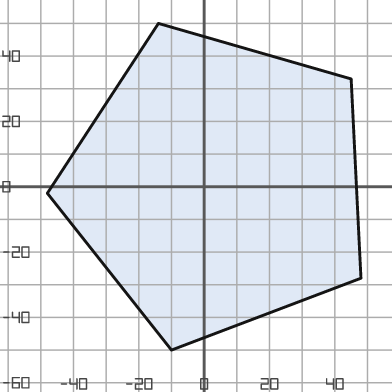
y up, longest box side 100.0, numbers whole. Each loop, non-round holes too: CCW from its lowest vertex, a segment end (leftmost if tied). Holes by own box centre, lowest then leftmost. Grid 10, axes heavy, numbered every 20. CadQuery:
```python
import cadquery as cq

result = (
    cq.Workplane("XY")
    .moveTo(-10.0, -50.0)
    .lineTo(48.0, -28.0)
    .lineTo(45.0, 33.0)
    .lineTo(-14.0, 50.0)
    .lineTo(-48.0, -2.0)
    .close()
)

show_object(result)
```